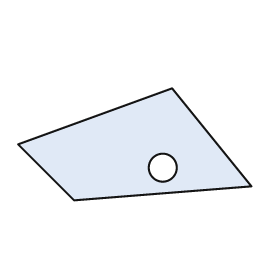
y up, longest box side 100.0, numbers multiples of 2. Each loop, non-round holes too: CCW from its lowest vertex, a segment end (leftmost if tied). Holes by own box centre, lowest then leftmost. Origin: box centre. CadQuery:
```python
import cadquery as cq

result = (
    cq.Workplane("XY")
    .moveTo(-26.0, -24.0)
    .lineTo(50.0, -18.0)
    .lineTo(16.0, 24.0)
    .lineTo(-50.0, 0.0)
    .close()
    .moveTo(12.0, -10.0)
    .circle(6.0)
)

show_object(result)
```